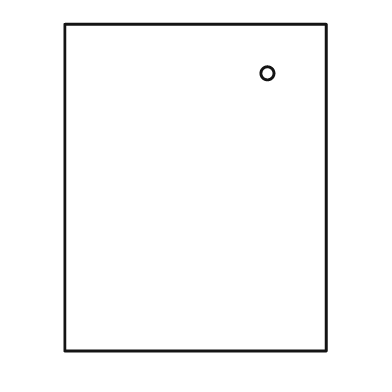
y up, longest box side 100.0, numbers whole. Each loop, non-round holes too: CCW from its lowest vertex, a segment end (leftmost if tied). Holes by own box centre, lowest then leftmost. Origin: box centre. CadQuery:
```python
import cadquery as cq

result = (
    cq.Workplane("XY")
    .moveTo(-40.0, -50.0)
    .lineTo(40.0, -50.0)
    .lineTo(40.0, 50.0)
    .lineTo(-40.0, 50.0)
    .close()
    .moveTo(22.0, 35.0)
    .circle(2.0)
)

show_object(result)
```